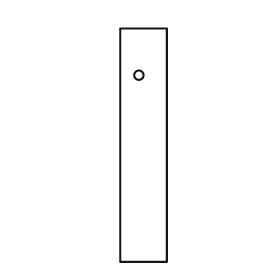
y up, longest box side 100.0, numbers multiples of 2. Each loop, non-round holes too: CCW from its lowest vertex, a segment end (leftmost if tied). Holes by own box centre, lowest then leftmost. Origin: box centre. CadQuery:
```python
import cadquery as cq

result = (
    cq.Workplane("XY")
    .moveTo(-10.0, -50.0)
    .lineTo(10.0, -50.0)
    .lineTo(10.0, 50.0)
    .lineTo(-10.0, 50.0)
    .close()
    .moveTo(-2.0, 30.0)
    .circle(2.0)
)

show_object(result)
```